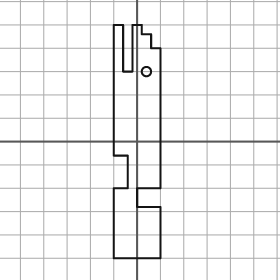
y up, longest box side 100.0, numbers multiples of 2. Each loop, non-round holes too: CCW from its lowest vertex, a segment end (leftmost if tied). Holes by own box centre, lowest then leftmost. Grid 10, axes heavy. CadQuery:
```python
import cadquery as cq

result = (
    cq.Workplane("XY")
    .moveTo(-10.0, -50.0)
    .lineTo(10.0, -50.0)
    .lineTo(10.0, -28.0)
    .lineTo(0.0, -28.0)
    .lineTo(0.0, -20.0)
    .lineTo(10.0, -20.0)
    .lineTo(10.0, 40.0)
    .lineTo(6.0, 40.0)
    .lineTo(6.0, 46.0)
    .lineTo(2.0, 46.0)
    .lineTo(2.0, 50.0)
    .lineTo(-2.0, 50.0)
    .lineTo(-2.0, 30.0)
    .lineTo(-6.0, 30.0)
    .lineTo(-6.0, 50.0)
    .lineTo(-10.0, 50.0)
    .lineTo(-10.0, -6.0)
    .lineTo(-4.0, -6.0)
    .lineTo(-4.0, -20.0)
    .lineTo(-10.0, -20.0)
    .close()
    .moveTo(4.0, 30.0)
    .circle(2.0)
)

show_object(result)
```